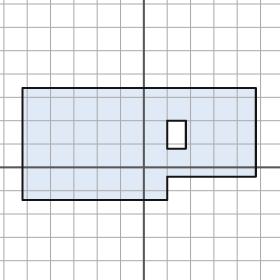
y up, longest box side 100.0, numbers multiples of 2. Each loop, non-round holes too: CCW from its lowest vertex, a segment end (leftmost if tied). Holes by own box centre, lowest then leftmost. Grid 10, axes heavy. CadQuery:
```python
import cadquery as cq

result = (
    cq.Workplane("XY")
    .moveTo(-52.0, -14.0)
    .lineTo(10.0, -14.0)
    .lineTo(10.0, -4.0)
    .lineTo(48.0, -4.0)
    .lineTo(48.0, 34.0)
    .lineTo(-52.0, 34.0)
    .close()
    .moveTo(10.0, 8.0)
    .lineTo(18.0, 8.0)
    .lineTo(18.0, 20.0)
    .lineTo(10.0, 20.0)
    .close()
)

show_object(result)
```